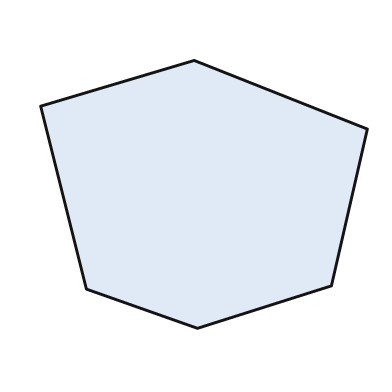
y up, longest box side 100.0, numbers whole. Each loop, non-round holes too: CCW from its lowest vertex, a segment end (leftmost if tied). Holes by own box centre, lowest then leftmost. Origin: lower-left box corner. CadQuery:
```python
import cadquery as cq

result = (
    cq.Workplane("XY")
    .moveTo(48.0, 0.0)
    .lineTo(89.0, 13.0)
    .lineTo(100.0, 61.0)
    .lineTo(47.0, 82.0)
    .lineTo(0.0, 68.0)
    .lineTo(14.0, 12.0)
    .close()
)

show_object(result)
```